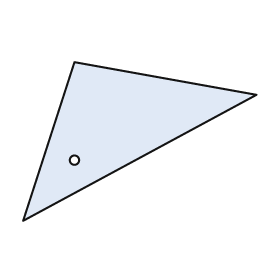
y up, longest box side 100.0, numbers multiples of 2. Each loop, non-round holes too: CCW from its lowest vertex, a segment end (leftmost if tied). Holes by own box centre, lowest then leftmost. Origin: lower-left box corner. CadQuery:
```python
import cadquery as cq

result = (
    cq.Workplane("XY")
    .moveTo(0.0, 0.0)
    .lineTo(100.0, 54.0)
    .lineTo(22.0, 68.0)
    .close()
    .moveTo(22.0, 26.0)
    .circle(2.0)
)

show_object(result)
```